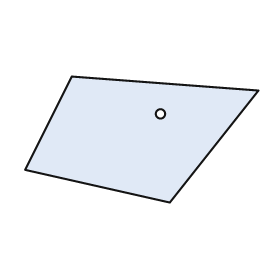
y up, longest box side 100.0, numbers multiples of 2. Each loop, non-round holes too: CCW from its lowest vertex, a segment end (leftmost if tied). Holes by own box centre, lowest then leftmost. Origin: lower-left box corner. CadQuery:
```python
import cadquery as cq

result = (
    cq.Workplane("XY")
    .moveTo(62.0, 0.0)
    .lineTo(100.0, 48.0)
    .lineTo(20.0, 54.0)
    .lineTo(0.0, 14.0)
    .close()
    .moveTo(58.0, 38.0)
    .circle(2.0)
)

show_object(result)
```